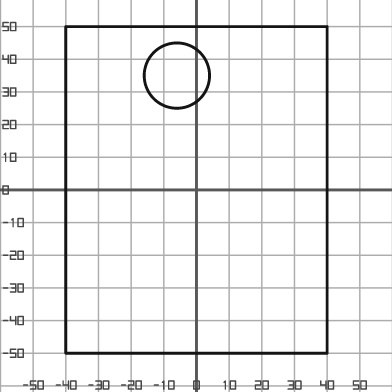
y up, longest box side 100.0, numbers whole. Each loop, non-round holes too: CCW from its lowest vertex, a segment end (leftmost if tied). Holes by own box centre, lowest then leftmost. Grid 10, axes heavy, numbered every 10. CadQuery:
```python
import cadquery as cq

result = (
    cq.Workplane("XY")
    .moveTo(-40.0, -50.0)
    .lineTo(40.0, -50.0)
    .lineTo(40.0, 50.0)
    .lineTo(-40.0, 50.0)
    .close()
    .moveTo(-6.0, 35.0)
    .circle(10.0)
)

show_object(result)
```